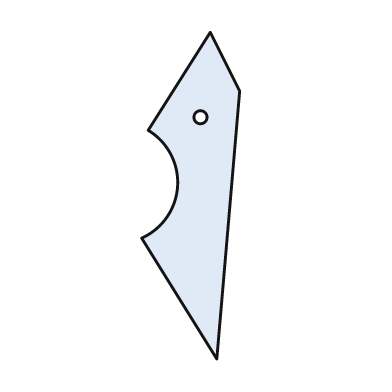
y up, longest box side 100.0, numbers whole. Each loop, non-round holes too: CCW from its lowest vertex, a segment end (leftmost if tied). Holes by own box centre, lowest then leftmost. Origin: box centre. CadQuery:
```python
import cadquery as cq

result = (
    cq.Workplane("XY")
    .moveTo(8.0, -50.0)
    .lineTo(15.0, 32.0)
    .lineTo(6.0, 50.0)
    .lineTo(-13.0, 20.0)
    .threePointArc((-4.0, 3.0), (-15.0, -13.0))
    .close()
    .moveTo(3.0, 24.0)
    .circle(2.0)
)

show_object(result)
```